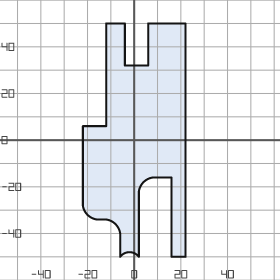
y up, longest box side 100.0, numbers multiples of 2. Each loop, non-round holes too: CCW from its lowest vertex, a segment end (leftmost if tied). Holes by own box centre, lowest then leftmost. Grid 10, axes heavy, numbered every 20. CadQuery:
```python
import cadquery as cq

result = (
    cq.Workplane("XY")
    .moveTo(-6.0, -50.0)
    .threePointArc((-2.0, -48.0), (2.0, -50.0))
    .lineTo(2.0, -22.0)
    .threePointArc((4.0, -18.0), (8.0, -16.0))
    .lineTo(16.0, -16.0)
    .lineTo(16.0, -50.0)
    .lineTo(22.0, -50.0)
    .lineTo(22.0, 50.0)
    .lineTo(6.0, 50.0)
    .lineTo(6.0, 32.0)
    .lineTo(-4.0, 32.0)
    .lineTo(-4.0, 50.0)
    .lineTo(-12.0, 50.0)
    .lineTo(-12.0, 6.0)
    .lineTo(-22.0, 6.0)
    .lineTo(-22.0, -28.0)
    .threePointArc((-20.0, -32.0), (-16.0, -34.0))
    .lineTo(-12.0, -34.0)
    .threePointArc((-8.0, -36.0), (-6.0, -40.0))
    .close()
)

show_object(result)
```